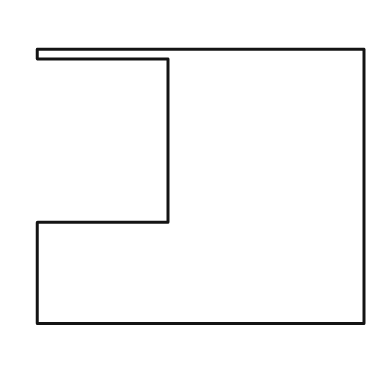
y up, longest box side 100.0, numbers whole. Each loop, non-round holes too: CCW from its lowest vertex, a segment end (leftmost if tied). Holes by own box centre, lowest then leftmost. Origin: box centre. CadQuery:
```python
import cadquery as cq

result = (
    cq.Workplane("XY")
    .moveTo(-50.0, -42.0)
    .lineTo(50.0, -42.0)
    .lineTo(50.0, 42.0)
    .lineTo(-50.0, 42.0)
    .lineTo(-50.0, 39.0)
    .lineTo(-10.0, 39.0)
    .lineTo(-10.0, -11.0)
    .lineTo(-50.0, -11.0)
    .close()
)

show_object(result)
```